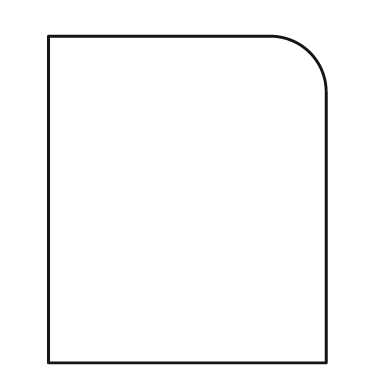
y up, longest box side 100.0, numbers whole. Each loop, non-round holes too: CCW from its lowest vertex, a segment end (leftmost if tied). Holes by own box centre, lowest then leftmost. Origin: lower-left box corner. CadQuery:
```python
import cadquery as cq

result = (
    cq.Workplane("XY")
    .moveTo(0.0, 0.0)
    .lineTo(85.0, 0.0)
    .lineTo(85.0, 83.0)
    .threePointArc((80.0, 95.0), (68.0, 100.0))
    .lineTo(0.0, 100.0)
    .close()
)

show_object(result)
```